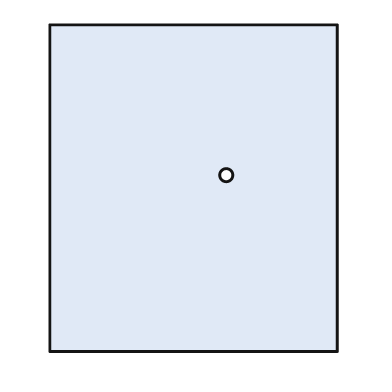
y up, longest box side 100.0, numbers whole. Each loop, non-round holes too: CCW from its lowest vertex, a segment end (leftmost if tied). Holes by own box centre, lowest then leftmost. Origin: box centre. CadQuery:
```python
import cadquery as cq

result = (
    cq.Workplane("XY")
    .moveTo(-44.0, -50.0)
    .lineTo(44.0, -50.0)
    .lineTo(44.0, 50.0)
    .lineTo(-44.0, 50.0)
    .close()
    .moveTo(10.0, 4.0)
    .circle(2.0)
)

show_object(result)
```